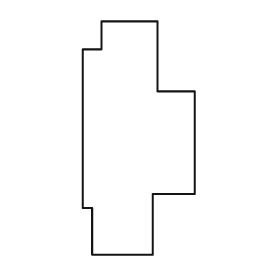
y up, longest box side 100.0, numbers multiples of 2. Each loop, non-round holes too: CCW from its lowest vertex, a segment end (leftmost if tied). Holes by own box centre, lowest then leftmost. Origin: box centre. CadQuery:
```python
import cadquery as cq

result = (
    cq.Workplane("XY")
    .moveTo(-20.0, -50.0)
    .lineTo(6.0, -50.0)
    .lineTo(6.0, -24.0)
    .lineTo(24.0, -24.0)
    .lineTo(24.0, 20.0)
    .lineTo(8.0, 20.0)
    .lineTo(8.0, 50.0)
    .lineTo(-16.0, 50.0)
    .lineTo(-16.0, 38.0)
    .lineTo(-24.0, 38.0)
    .lineTo(-24.0, -30.0)
    .lineTo(-20.0, -30.0)
    .close()
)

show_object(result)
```